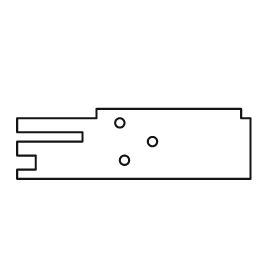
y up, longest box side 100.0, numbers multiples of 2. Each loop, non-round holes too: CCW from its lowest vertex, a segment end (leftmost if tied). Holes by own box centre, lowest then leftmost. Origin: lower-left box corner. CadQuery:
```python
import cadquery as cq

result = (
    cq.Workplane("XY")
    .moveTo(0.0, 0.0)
    .lineTo(100.0, 0.0)
    .lineTo(100.0, 26.0)
    .lineTo(96.0, 26.0)
    .lineTo(96.0, 30.0)
    .lineTo(34.0, 30.0)
    .lineTo(34.0, 26.0)
    .lineTo(0.0, 26.0)
    .lineTo(0.0, 20.0)
    .lineTo(28.0, 20.0)
    .lineTo(28.0, 16.0)
    .lineTo(0.0, 16.0)
    .lineTo(0.0, 10.0)
    .lineTo(8.0, 10.0)
    .lineTo(8.0, 4.0)
    .lineTo(0.0, 4.0)
    .close()
    .moveTo(46.0, 8.0)
    .circle(2.0)
    .moveTo(58.0, 16.0)
    .circle(2.0)
    .moveTo(44.0, 24.0)
    .circle(2.0)
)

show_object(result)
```